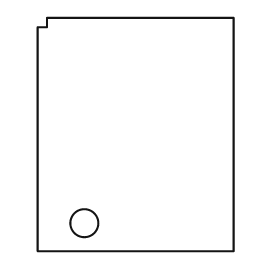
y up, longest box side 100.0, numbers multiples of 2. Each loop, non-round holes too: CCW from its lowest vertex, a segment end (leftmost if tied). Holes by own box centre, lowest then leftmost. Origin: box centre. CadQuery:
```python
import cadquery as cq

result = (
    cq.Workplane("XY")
    .moveTo(-42.0, -50.0)
    .lineTo(42.0, -50.0)
    .lineTo(42.0, 50.0)
    .lineTo(-38.0, 50.0)
    .lineTo(-38.0, 46.0)
    .lineTo(-42.0, 46.0)
    .close()
    .moveTo(-22.0, -38.0)
    .circle(6.0)
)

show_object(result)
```